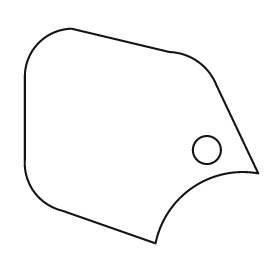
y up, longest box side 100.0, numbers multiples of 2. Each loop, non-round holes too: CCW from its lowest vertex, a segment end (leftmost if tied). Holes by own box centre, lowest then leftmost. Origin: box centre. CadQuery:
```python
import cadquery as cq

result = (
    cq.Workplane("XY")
    .moveTo(6.0, -46.0)
    .threePointArc((22.0, -22.0), (50.0, -16.0))
    .lineTo(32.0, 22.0)
    .threePointArc((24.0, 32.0), (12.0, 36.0))
    .lineTo(-30.0, 46.0)
    .threePointArc((-44.0, 40.0), (-50.0, 26.0))
    .lineTo(-50.0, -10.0)
    .threePointArc((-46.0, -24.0), (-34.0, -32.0))
    .close()
    .moveTo(28.0, -6.0)
    .circle(6.0)
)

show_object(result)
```